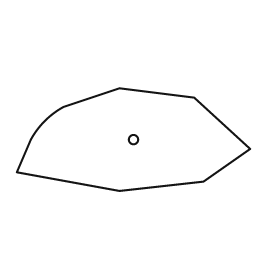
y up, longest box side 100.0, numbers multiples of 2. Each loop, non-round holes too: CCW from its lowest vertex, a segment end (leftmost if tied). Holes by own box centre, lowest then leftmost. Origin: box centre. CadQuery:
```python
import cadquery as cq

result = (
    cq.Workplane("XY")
    .moveTo(-6.0, -22.0)
    .lineTo(30.0, -18.0)
    .lineTo(50.0, -4.0)
    .lineTo(26.0, 18.0)
    .lineTo(-6.0, 22.0)
    .lineTo(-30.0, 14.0)
    .threePointArc((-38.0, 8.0), (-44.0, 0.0))
    .lineTo(-50.0, -14.0)
    .close()
    .moveTo(0.0, 0.0)
    .circle(2.0)
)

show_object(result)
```